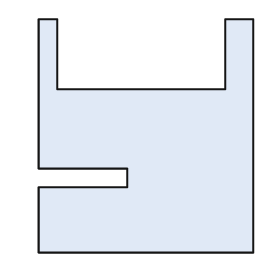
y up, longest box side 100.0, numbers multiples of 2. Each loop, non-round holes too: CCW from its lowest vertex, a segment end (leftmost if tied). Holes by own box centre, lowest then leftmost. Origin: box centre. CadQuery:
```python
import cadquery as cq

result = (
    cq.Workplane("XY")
    .moveTo(-46.0, -50.0)
    .lineTo(46.0, -50.0)
    .lineTo(46.0, 50.0)
    .lineTo(34.0, 50.0)
    .lineTo(34.0, 20.0)
    .lineTo(-38.0, 20.0)
    .lineTo(-38.0, 50.0)
    .lineTo(-46.0, 50.0)
    .lineTo(-46.0, -14.0)
    .lineTo(-8.0, -14.0)
    .lineTo(-8.0, -22.0)
    .lineTo(-46.0, -22.0)
    .close()
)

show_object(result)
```